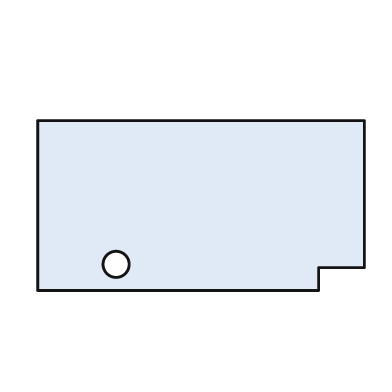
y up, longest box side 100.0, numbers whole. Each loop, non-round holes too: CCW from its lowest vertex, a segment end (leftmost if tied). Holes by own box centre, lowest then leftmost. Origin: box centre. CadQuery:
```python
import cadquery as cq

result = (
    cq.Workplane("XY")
    .moveTo(-50.0, -26.0)
    .lineTo(36.0, -26.0)
    .lineTo(36.0, -19.0)
    .lineTo(50.0, -19.0)
    .lineTo(50.0, 26.0)
    .lineTo(-50.0, 26.0)
    .close()
    .moveTo(-26.0, -18.0)
    .circle(4.0)
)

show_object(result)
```